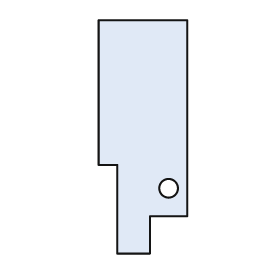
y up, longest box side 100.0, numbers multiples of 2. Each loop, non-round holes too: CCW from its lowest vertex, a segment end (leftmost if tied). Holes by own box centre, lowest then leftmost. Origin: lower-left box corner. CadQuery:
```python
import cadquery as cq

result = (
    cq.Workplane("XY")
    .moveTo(8.0, 0.0)
    .lineTo(22.0, 0.0)
    .lineTo(22.0, 16.0)
    .lineTo(38.0, 16.0)
    .lineTo(38.0, 100.0)
    .lineTo(0.0, 100.0)
    .lineTo(0.0, 38.0)
    .lineTo(8.0, 38.0)
    .close()
    .moveTo(30.0, 28.0)
    .circle(4.0)
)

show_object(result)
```